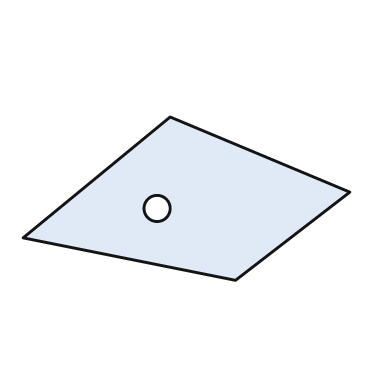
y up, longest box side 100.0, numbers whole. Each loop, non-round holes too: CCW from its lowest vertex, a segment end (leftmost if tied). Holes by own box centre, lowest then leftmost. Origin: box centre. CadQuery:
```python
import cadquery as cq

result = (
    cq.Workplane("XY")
    .moveTo(15.0, -25.0)
    .lineTo(50.0, 2.0)
    .lineTo(-5.0, 25.0)
    .lineTo(-50.0, -12.0)
    .close()
    .moveTo(-9.0, -3.0)
    .circle(4.0)
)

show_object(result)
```